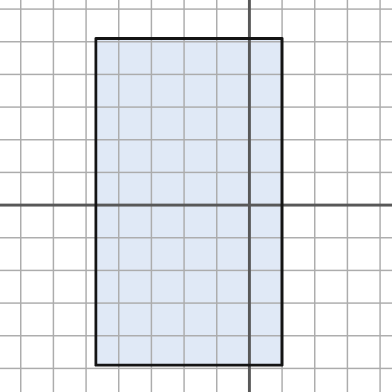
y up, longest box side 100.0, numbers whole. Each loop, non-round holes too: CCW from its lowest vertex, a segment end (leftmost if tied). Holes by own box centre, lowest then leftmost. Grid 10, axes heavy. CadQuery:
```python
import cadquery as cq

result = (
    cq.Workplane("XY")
    .moveTo(-47.0, -49.0)
    .lineTo(10.0, -49.0)
    .lineTo(10.0, 51.0)
    .lineTo(-47.0, 51.0)
    .close()
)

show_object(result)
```